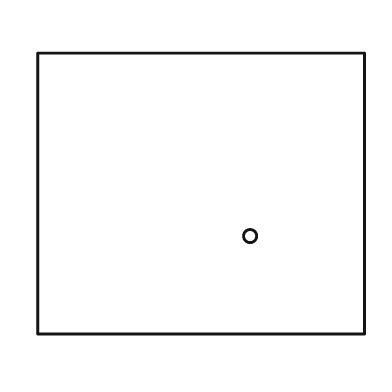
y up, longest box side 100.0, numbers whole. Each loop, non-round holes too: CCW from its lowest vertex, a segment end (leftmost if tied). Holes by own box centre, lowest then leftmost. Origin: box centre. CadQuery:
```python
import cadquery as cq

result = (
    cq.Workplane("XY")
    .moveTo(-50.0, -43.0)
    .lineTo(50.0, -43.0)
    .lineTo(50.0, 43.0)
    .lineTo(-50.0, 43.0)
    .close()
    .moveTo(15.0, -13.0)
    .circle(2.0)
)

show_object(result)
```